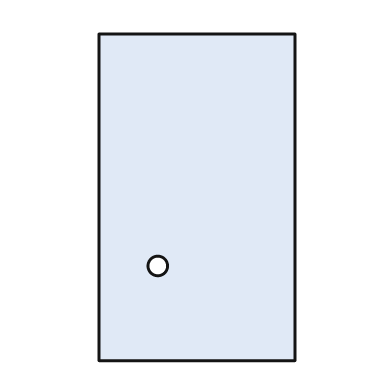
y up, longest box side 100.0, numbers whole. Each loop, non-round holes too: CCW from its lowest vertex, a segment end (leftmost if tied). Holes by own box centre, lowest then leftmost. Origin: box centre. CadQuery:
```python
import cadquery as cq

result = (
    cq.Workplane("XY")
    .moveTo(-30.0, -50.0)
    .lineTo(30.0, -50.0)
    .lineTo(30.0, 50.0)
    .lineTo(-30.0, 50.0)
    .close()
    .moveTo(-12.0, -21.0)
    .circle(3.0)
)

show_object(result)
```